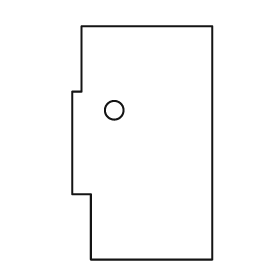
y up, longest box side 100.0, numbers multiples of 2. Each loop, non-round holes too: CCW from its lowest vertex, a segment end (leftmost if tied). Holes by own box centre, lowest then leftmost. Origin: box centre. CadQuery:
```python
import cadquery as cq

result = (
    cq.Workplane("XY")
    .moveTo(-22.0, -50.0)
    .lineTo(30.0, -50.0)
    .lineTo(30.0, 50.0)
    .lineTo(-26.0, 50.0)
    .lineTo(-26.0, 22.0)
    .lineTo(-30.0, 22.0)
    .lineTo(-30.0, -22.0)
    .lineTo(-22.0, -22.0)
    .close()
    .moveTo(-12.0, 14.0)
    .circle(4.0)
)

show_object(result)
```